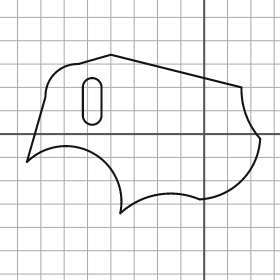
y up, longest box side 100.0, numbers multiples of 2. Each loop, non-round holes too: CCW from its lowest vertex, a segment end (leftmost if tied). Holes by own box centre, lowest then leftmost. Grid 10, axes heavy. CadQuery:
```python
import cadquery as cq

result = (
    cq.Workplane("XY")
    .moveTo(-36.0, -34.0)
    .threePointArc((-20.0, -26.0), (-2.0, -28.0))
    .threePointArc((16.0, -20.0), (24.0, -2.0))
    .threePointArc((18.0, 8.0), (16.0, 20.0))
    .lineTo(-40.0, 34.0)
    .lineTo(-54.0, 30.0)
    .threePointArc((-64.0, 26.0), (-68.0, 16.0))
    .lineTo(-76.0, -12.0)
    .threePointArc((-48.0, -8.0), (-36.0, -34.0))
    .close()
    .moveTo(-52.0, 8.0)
    .threePointArc((-48.0, 4.0), (-44.0, 8.0))
    .lineTo(-44.0, 20.0)
    .threePointArc((-48.0, 24.0), (-52.0, 20.0))
    .close()
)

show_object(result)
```